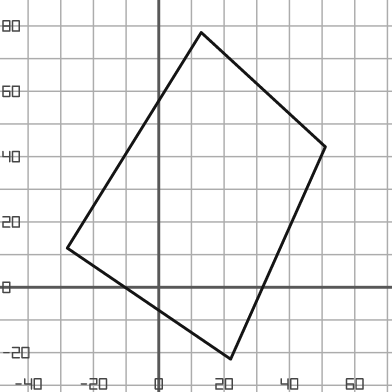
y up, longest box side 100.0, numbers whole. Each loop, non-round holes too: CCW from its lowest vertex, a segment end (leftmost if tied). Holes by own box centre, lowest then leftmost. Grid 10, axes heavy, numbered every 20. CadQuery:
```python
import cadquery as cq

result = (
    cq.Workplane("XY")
    .moveTo(22.0, -22.0)
    .lineTo(51.0, 43.0)
    .lineTo(13.0, 78.0)
    .lineTo(-28.0, 12.0)
    .close()
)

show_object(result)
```